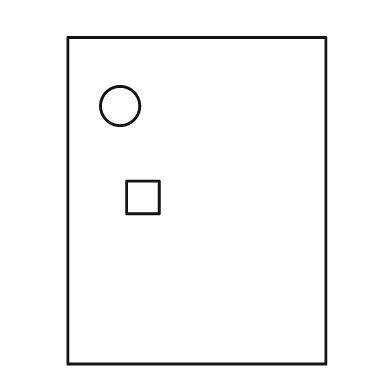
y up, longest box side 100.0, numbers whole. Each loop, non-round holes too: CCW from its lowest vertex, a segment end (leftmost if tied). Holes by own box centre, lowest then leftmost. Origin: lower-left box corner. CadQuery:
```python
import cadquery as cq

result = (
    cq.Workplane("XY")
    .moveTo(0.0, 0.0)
    .lineTo(79.0, 0.0)
    .lineTo(79.0, 100.0)
    .lineTo(0.0, 100.0)
    .close()
    .moveTo(18.0, 46.0)
    .lineTo(28.0, 46.0)
    .lineTo(28.0, 56.0)
    .lineTo(18.0, 56.0)
    .close()
    .moveTo(16.0, 79.0)
    .circle(6.0)
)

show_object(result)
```